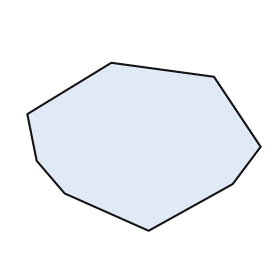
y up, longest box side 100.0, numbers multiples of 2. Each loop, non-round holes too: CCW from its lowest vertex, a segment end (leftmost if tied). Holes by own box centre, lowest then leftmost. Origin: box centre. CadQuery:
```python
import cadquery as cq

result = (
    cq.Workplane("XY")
    .moveTo(2.0, -36.0)
    .lineTo(38.0, -16.0)
    .lineTo(50.0, 0.0)
    .lineTo(30.0, 30.0)
    .lineTo(-14.0, 36.0)
    .lineTo(-50.0, 14.0)
    .lineTo(-46.0, -6.0)
    .lineTo(-34.0, -20.0)
    .close()
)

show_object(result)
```